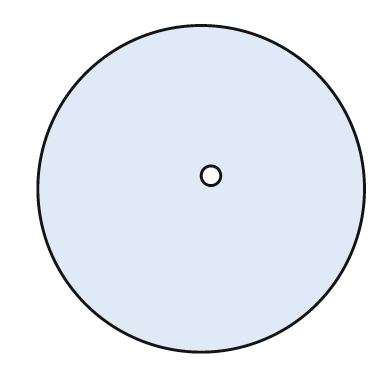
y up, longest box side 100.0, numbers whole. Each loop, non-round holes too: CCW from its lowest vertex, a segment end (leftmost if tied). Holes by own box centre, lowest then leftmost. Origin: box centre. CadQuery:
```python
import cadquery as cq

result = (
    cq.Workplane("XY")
    .moveTo(0.0, 0.0)
    .circle(50.0)
    .moveTo(3.0, 4.0)
    .circle(3.0)
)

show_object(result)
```